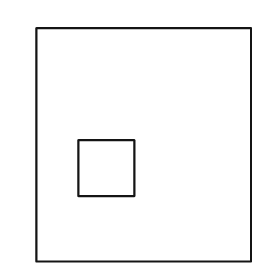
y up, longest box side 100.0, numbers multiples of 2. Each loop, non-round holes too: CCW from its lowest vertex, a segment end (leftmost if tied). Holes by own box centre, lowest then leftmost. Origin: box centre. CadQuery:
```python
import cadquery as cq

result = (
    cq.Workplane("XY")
    .moveTo(-46.0, -50.0)
    .lineTo(46.0, -50.0)
    .lineTo(46.0, 50.0)
    .lineTo(-46.0, 50.0)
    .close()
    .moveTo(-28.0, -22.0)
    .lineTo(-4.0, -22.0)
    .lineTo(-4.0, 2.0)
    .lineTo(-28.0, 2.0)
    .close()
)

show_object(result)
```